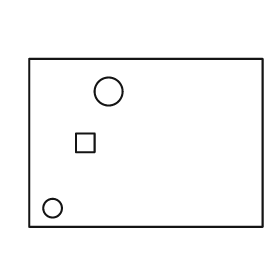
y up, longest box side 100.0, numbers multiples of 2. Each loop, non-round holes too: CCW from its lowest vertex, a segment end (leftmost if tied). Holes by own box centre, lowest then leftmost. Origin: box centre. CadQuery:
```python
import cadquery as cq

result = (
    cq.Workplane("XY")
    .moveTo(-50.0, -36.0)
    .lineTo(50.0, -36.0)
    .lineTo(50.0, 36.0)
    .lineTo(-50.0, 36.0)
    .close()
    .moveTo(-40.0, -28.0)
    .circle(4.0)
    .moveTo(-30.0, -4.0)
    .lineTo(-22.0, -4.0)
    .lineTo(-22.0, 4.0)
    .lineTo(-30.0, 4.0)
    .close()
    .moveTo(-16.0, 22.0)
    .circle(6.0)
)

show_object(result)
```